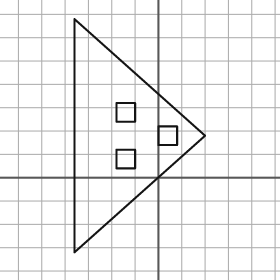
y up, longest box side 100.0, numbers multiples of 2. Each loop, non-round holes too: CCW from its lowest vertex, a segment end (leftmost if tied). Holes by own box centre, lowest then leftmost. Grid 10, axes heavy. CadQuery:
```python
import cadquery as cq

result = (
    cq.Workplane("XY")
    .moveTo(-36.0, -32.0)
    .lineTo(20.0, 18.0)
    .lineTo(-36.0, 68.0)
    .close()
    .moveTo(-18.0, 4.0)
    .lineTo(-10.0, 4.0)
    .lineTo(-10.0, 12.0)
    .lineTo(-18.0, 12.0)
    .close()
    .moveTo(0.0, 14.0)
    .lineTo(8.0, 14.0)
    .lineTo(8.0, 22.0)
    .lineTo(0.0, 22.0)
    .close()
    .moveTo(-18.0, 24.0)
    .lineTo(-10.0, 24.0)
    .lineTo(-10.0, 32.0)
    .lineTo(-18.0, 32.0)
    .close()
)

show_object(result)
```